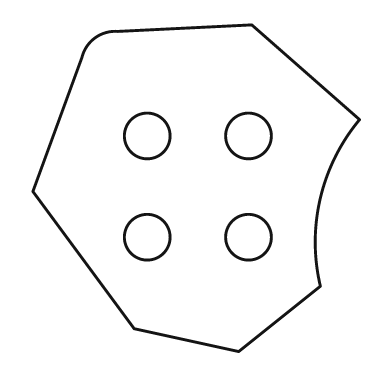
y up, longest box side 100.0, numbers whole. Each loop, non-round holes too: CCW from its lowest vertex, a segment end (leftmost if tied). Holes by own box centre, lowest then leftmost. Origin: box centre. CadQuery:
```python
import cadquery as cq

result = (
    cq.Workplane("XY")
    .moveTo(13.0, -50.0)
    .lineTo(38.0, -30.0)
    .threePointArc((38.0, -3.0), (50.0, 21.0))
    .lineTo(17.0, 50.0)
    .lineTo(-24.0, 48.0)
    .threePointArc((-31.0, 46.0), (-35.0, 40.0))
    .lineTo(-50.0, -1.0)
    .lineTo(-19.0, -43.0)
    .close()
    .moveTo(-15.0, -15.0)
    .circle(7.0)
    .moveTo(16.0, -15.0)
    .circle(7.0)
    .moveTo(-15.0, 16.0)
    .circle(7.0)
    .moveTo(16.0, 16.0)
    .circle(7.0)
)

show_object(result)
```